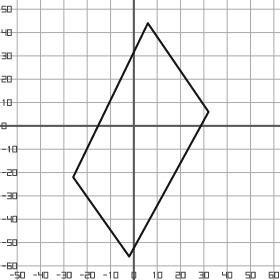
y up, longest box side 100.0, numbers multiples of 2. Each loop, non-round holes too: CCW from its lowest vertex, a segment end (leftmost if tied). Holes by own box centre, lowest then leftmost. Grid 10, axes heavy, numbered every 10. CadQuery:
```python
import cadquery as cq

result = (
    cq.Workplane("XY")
    .moveTo(-2.0, -56.0)
    .lineTo(32.0, 6.0)
    .lineTo(6.0, 44.0)
    .lineTo(-26.0, -22.0)
    .close()
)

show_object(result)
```